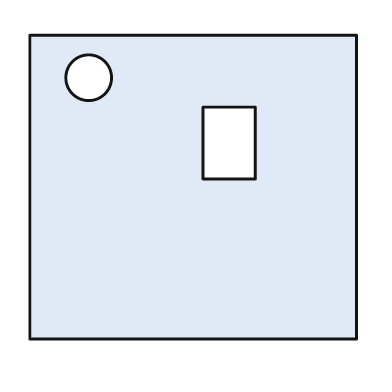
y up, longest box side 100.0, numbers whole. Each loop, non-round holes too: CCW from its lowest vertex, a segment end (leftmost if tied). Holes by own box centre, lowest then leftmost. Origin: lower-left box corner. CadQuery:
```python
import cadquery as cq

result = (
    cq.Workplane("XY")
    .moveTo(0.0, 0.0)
    .lineTo(100.0, 0.0)
    .lineTo(100.0, 93.0)
    .lineTo(0.0, 93.0)
    .close()
    .moveTo(53.0, 49.0)
    .lineTo(69.0, 49.0)
    .lineTo(69.0, 71.0)
    .lineTo(53.0, 71.0)
    .close()
    .moveTo(18.0, 80.0)
    .circle(7.0)
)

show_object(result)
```